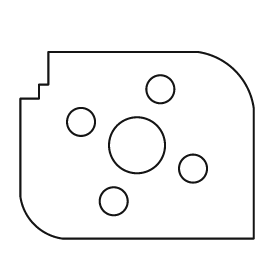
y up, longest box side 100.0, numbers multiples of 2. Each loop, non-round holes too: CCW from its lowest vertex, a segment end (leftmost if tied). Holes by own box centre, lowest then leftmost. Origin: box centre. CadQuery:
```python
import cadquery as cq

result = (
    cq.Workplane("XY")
    .moveTo(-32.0, -40.0)
    .lineTo(50.0, -40.0)
    .lineTo(50.0, 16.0)
    .threePointArc((42.0, 32.0), (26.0, 40.0))
    .lineTo(-38.0, 40.0)
    .lineTo(-38.0, 26.0)
    .lineTo(-42.0, 26.0)
    .lineTo(-42.0, 20.0)
    .lineTo(-50.0, 20.0)
    .lineTo(-50.0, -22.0)
    .threePointArc((-44.0, -34.0), (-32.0, -40.0))
    .close()
    .moveTo(-10.0, -24.0)
    .circle(6.0)
    .moveTo(24.0, -10.0)
    .circle(6.0)
    .moveTo(0.0, 0.0)
    .circle(12.0)
    .moveTo(-24.0, 10.0)
    .circle(6.0)
    .moveTo(10.0, 24.0)
    .circle(6.0)
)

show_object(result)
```